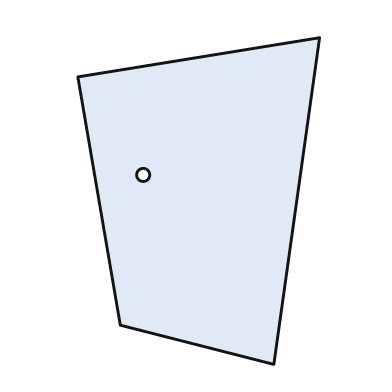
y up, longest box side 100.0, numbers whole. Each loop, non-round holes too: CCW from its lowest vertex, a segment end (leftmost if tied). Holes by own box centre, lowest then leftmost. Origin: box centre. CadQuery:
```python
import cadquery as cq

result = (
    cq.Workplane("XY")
    .moveTo(23.0, -50.0)
    .lineTo(37.0, 50.0)
    .lineTo(-37.0, 38.0)
    .lineTo(-24.0, -38.0)
    .close()
    .moveTo(-17.0, 8.0)
    .circle(2.0)
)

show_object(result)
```